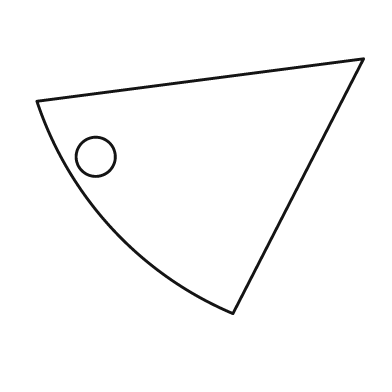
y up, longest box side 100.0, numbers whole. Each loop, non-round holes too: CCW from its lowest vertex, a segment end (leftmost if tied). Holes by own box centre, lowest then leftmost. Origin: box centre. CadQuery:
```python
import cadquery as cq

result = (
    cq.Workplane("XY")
    .moveTo(10.0, -39.0)
    .lineTo(50.0, 39.0)
    .lineTo(-50.0, 26.0)
    .threePointArc((-27.0, -13.0), (10.0, -39.0))
    .close()
    .moveTo(-32.0, 9.0)
    .circle(6.0)
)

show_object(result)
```